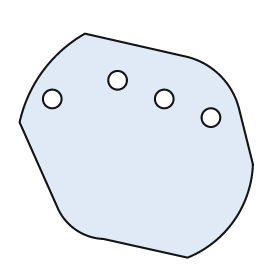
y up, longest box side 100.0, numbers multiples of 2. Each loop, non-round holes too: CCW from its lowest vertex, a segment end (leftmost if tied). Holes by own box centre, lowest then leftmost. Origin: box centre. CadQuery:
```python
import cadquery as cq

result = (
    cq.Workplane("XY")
    .moveTo(22.0, -48.0)
    .threePointArc((42.0, -32.0), (50.0, -8.0))
    .lineTo(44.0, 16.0)
    .threePointArc((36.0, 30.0), (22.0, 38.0))
    .lineTo(-22.0, 48.0)
    .threePointArc((-40.0, 32.0), (-50.0, 10.0))
    .lineTo(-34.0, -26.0)
    .threePointArc((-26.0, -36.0), (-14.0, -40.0))
    .close()
    .moveTo(32.0, 12.0)
    .circle(4.0)
    .moveTo(-36.0, 20.0)
    .circle(4.0)
    .moveTo(12.0, 20.0)
    .circle(4.0)
    .moveTo(-8.0, 28.0)
    .circle(4.0)
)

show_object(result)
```